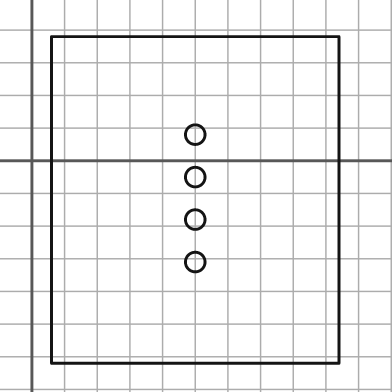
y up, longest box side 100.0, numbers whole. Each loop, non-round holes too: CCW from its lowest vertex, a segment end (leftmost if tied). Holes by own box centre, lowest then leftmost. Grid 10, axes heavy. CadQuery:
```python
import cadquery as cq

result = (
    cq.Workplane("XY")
    .moveTo(6.0, -62.0)
    .lineTo(94.0, -62.0)
    .lineTo(94.0, 38.0)
    .lineTo(6.0, 38.0)
    .close()
    .moveTo(50.0, -31.0)
    .circle(3.0)
    .moveTo(50.0, -18.0)
    .circle(3.0)
    .moveTo(50.0, -5.0)
    .circle(3.0)
    .moveTo(50.0, 8.0)
    .circle(3.0)
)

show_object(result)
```